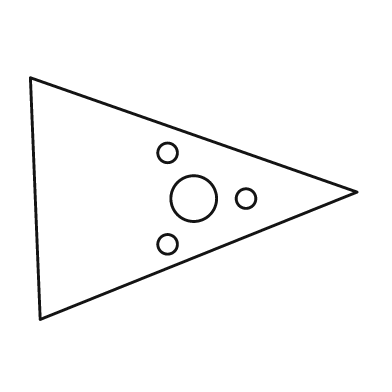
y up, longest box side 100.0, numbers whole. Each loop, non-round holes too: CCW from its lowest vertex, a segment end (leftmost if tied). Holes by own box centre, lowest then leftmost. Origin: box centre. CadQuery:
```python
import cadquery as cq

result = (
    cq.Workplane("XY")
    .moveTo(-47.0, -37.0)
    .lineTo(50.0, 2.0)
    .lineTo(-50.0, 37.0)
    .close()
    .moveTo(-8.0, -14.0)
    .circle(3.0)
    .moveTo(0.0, 0.0)
    .circle(7.0)
    .moveTo(16.0, 0.0)
    .circle(3.0)
    .moveTo(-8.0, 14.0)
    .circle(3.0)
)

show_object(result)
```